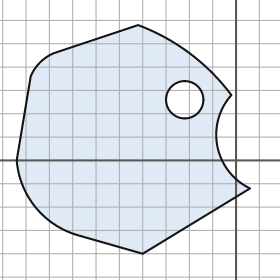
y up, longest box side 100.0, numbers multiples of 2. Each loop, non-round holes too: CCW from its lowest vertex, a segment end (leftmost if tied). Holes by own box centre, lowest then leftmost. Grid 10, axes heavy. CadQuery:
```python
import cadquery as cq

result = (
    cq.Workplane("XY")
    .moveTo(-40.0, -40.0)
    .lineTo(6.0, -12.0)
    .threePointArc((-8.0, 6.0), (-2.0, 28.0))
    .threePointArc((-20.0, 46.0), (-42.0, 58.0))
    .lineTo(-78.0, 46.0)
    .threePointArc((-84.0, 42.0), (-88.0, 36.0))
    .lineTo(-94.0, 0.0)
    .threePointArc((-86.0, -20.0), (-68.0, -32.0))
    .close()
    .moveTo(-22.0, 26.0)
    .circle(8.0)
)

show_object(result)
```